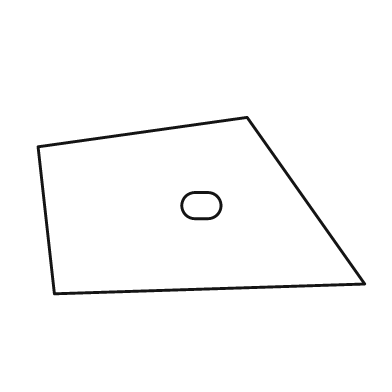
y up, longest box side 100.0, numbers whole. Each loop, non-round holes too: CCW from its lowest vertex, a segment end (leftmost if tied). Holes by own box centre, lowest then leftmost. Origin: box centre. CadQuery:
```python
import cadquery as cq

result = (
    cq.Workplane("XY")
    .moveTo(-45.0, -27.0)
    .lineTo(50.0, -24.0)
    .lineTo(14.0, 27.0)
    .lineTo(-50.0, 18.0)
    .close()
    .moveTo(-2.0, -4.0)
    .lineTo(2.0, -4.0)
    .threePointArc((6.0, 0.0), (2.0, 4.0))
    .lineTo(-2.0, 4.0)
    .threePointArc((-6.0, 0.0), (-2.0, -4.0))
    .close()
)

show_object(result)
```